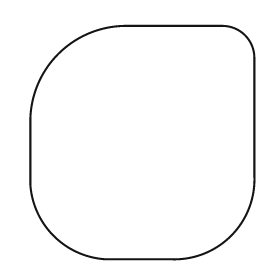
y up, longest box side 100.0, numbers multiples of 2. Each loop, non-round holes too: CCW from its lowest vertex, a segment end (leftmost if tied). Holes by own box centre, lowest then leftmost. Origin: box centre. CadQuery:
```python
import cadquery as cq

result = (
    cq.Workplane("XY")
    .moveTo(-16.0, -50.0)
    .lineTo(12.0, -50.0)
    .threePointArc((38.0, -40.0), (48.0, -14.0))
    .lineTo(48.0, 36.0)
    .threePointArc((44.0, 46.0), (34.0, 50.0))
    .lineTo(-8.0, 50.0)
    .threePointArc((-36.0, 38.0), (-48.0, 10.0))
    .lineTo(-48.0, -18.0)
    .threePointArc((-38.0, -40.0), (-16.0, -50.0))
    .close()
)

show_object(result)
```